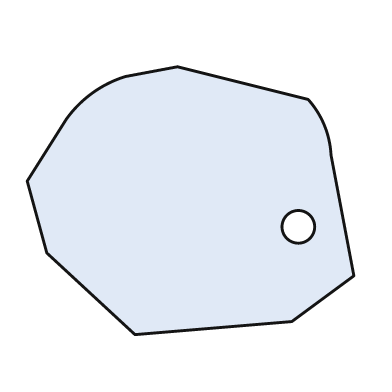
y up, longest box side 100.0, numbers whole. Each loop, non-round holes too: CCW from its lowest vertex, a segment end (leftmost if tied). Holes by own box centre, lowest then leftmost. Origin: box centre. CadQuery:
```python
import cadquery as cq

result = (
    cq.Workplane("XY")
    .moveTo(-17.0, -41.0)
    .lineTo(31.0, -37.0)
    .lineTo(50.0, -23.0)
    .lineTo(43.0, 14.0)
    .threePointArc((41.0, 23.0), (36.0, 31.0))
    .lineTo(-4.0, 41.0)
    .lineTo(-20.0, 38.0)
    .threePointArc((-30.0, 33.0), (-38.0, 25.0))
    .lineTo(-50.0, 6.0)
    .lineTo(-44.0, -16.0)
    .close()
    .moveTo(33.0, -8.0)
    .circle(5.0)
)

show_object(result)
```